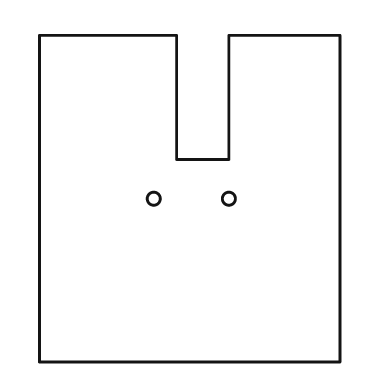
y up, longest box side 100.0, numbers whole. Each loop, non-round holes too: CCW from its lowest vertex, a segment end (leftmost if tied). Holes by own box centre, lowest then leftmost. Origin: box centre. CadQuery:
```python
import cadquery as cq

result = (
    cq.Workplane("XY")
    .moveTo(-46.0, -50.0)
    .lineTo(46.0, -50.0)
    .lineTo(46.0, 50.0)
    .lineTo(12.0, 50.0)
    .lineTo(12.0, 12.0)
    .lineTo(-4.0, 12.0)
    .lineTo(-4.0, 50.0)
    .lineTo(-46.0, 50.0)
    .close()
    .moveTo(-11.0, 0.0)
    .circle(2.0)
    .moveTo(12.0, 0.0)
    .circle(2.0)
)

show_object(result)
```